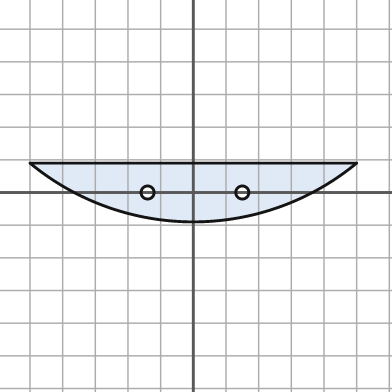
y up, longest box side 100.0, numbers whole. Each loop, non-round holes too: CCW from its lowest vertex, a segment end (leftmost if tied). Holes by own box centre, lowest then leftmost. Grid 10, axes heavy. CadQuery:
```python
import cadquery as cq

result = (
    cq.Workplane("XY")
    .moveTo(-50.0, 9.0)
    .threePointArc((0.0, -9.0), (50.0, 9.0))
    .close()
    .moveTo(-14.0, 0.0)
    .circle(2.0)
    .moveTo(15.0, 0.0)
    .circle(2.0)
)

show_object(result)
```